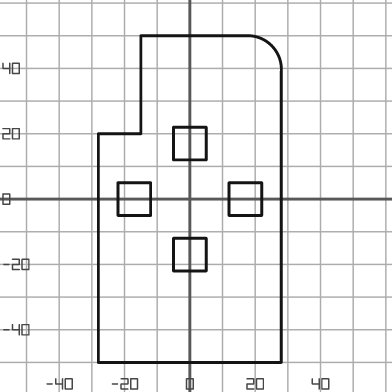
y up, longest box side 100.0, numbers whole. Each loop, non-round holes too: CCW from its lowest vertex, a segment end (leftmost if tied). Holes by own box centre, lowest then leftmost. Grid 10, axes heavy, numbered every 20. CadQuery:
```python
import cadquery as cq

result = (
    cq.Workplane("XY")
    .moveTo(-28.0, -50.0)
    .lineTo(28.0, -50.0)
    .lineTo(28.0, 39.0)
    .threePointArc((25.0, 47.0), (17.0, 50.0))
    .lineTo(-15.0, 50.0)
    .lineTo(-15.0, 20.0)
    .lineTo(-28.0, 20.0)
    .close()
    .moveTo(-5.0, -22.0)
    .lineTo(5.0, -22.0)
    .lineTo(5.0, -12.0)
    .lineTo(-5.0, -12.0)
    .close()
    .moveTo(-22.0, -5.0)
    .lineTo(-12.0, -5.0)
    .lineTo(-12.0, 5.0)
    .lineTo(-22.0, 5.0)
    .close()
    .moveTo(12.0, -5.0)
    .lineTo(22.0, -5.0)
    .lineTo(22.0, 5.0)
    .lineTo(12.0, 5.0)
    .close()
    .moveTo(-5.0, 12.0)
    .lineTo(5.0, 12.0)
    .lineTo(5.0, 22.0)
    .lineTo(-5.0, 22.0)
    .close()
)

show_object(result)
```